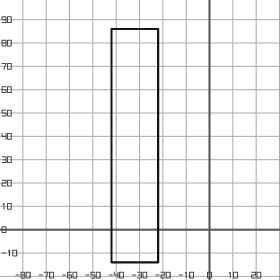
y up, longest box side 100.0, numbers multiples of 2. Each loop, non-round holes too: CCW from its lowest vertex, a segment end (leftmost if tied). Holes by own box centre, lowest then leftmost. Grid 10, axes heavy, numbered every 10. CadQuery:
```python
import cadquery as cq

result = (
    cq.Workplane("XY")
    .moveTo(-42.0, -14.0)
    .lineTo(-22.0, -14.0)
    .lineTo(-22.0, 86.0)
    .lineTo(-42.0, 86.0)
    .close()
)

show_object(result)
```